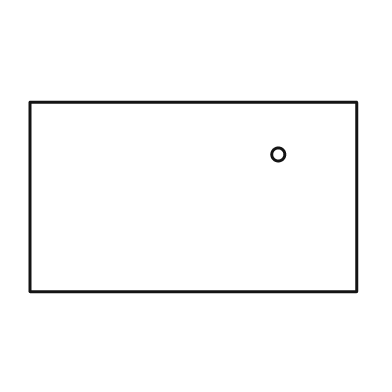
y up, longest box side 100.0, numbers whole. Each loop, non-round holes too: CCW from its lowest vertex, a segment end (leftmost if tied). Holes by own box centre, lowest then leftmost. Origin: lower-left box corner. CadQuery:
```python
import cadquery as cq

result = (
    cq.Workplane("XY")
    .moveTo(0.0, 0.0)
    .lineTo(100.0, 0.0)
    .lineTo(100.0, 58.0)
    .lineTo(0.0, 58.0)
    .close()
    .moveTo(76.0, 42.0)
    .circle(2.0)
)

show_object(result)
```